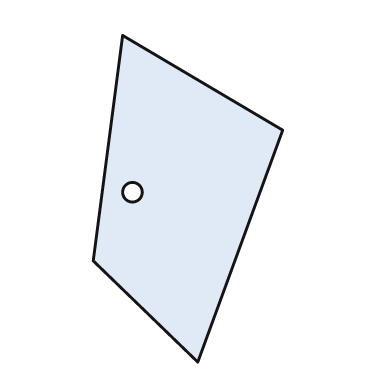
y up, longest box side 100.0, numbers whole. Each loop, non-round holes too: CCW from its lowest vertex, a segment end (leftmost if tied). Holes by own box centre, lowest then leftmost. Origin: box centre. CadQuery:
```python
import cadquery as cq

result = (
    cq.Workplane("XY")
    .moveTo(3.0, -50.0)
    .lineTo(29.0, 21.0)
    .lineTo(-20.0, 50.0)
    .lineTo(-29.0, -19.0)
    .close()
    .moveTo(-17.0, 2.0)
    .circle(3.0)
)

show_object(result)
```